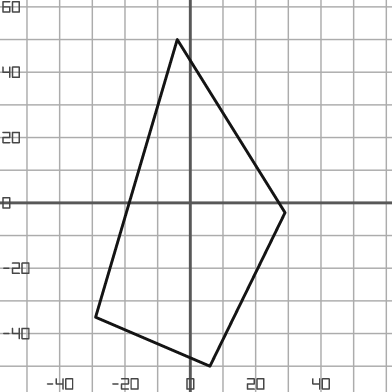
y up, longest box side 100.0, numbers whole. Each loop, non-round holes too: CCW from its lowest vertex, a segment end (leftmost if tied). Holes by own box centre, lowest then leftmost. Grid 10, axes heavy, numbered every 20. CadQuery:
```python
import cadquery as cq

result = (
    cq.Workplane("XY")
    .moveTo(6.0, -50.0)
    .lineTo(29.0, -3.0)
    .lineTo(-4.0, 50.0)
    .lineTo(-29.0, -35.0)
    .close()
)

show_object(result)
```